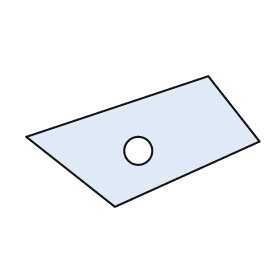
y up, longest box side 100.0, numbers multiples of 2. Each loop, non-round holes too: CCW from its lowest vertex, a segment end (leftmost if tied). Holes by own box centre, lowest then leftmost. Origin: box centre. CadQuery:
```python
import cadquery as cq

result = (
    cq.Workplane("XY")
    .moveTo(-12.0, -28.0)
    .lineTo(50.0, 0.0)
    .lineTo(28.0, 28.0)
    .lineTo(-50.0, 2.0)
    .close()
    .moveTo(-2.0, -4.0)
    .circle(6.0)
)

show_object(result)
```